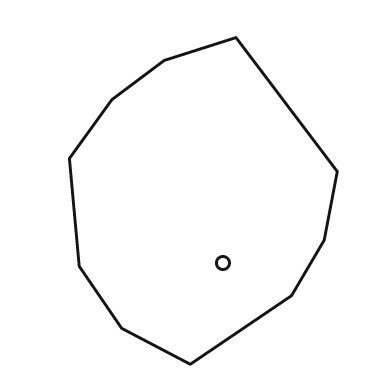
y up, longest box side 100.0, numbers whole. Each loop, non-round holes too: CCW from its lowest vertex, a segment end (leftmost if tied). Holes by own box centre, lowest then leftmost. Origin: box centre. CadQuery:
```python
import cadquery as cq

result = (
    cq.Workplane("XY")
    .moveTo(-4.0, -50.0)
    .lineTo(27.0, -29.0)
    .lineTo(37.0, -12.0)
    .lineTo(41.0, 9.0)
    .lineTo(10.0, 50.0)
    .lineTo(-12.0, 43.0)
    .lineTo(-28.0, 31.0)
    .lineTo(-41.0, 13.0)
    .lineTo(-38.0, -20.0)
    .lineTo(-25.0, -39.0)
    .close()
    .moveTo(6.0, -19.0)
    .circle(2.0)
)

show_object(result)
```